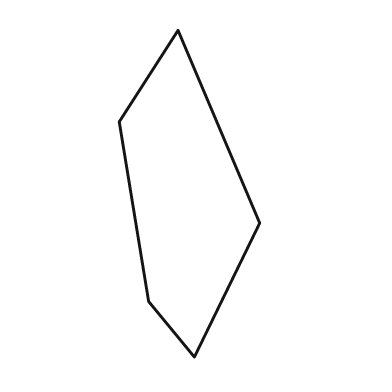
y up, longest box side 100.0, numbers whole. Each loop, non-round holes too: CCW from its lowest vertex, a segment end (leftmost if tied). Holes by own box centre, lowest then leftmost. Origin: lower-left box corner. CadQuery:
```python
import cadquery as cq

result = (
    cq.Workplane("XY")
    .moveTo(23.0, 0.0)
    .lineTo(43.0, 41.0)
    .lineTo(18.0, 100.0)
    .lineTo(0.0, 72.0)
    .lineTo(9.0, 17.0)
    .close()
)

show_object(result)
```